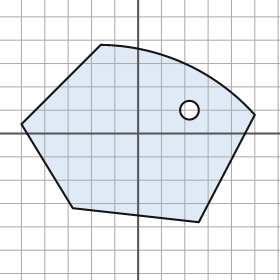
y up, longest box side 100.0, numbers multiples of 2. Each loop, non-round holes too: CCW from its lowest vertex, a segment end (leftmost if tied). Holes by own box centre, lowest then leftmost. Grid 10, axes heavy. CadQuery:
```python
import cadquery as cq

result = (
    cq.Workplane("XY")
    .moveTo(26.0, -38.0)
    .lineTo(50.0, 8.0)
    .threePointArc((20.0, 30.0), (-16.0, 38.0))
    .lineTo(-50.0, 4.0)
    .lineTo(-28.0, -32.0)
    .close()
    .moveTo(22.0, 10.0)
    .circle(4.0)
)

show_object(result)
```